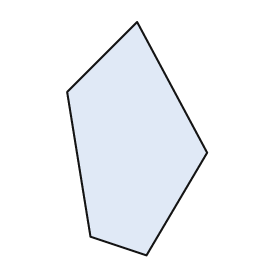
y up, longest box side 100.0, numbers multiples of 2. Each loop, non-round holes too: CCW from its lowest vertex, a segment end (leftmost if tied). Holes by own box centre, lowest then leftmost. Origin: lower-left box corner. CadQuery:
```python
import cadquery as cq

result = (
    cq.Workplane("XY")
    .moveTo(34.0, 0.0)
    .lineTo(60.0, 44.0)
    .lineTo(30.0, 100.0)
    .lineTo(0.0, 70.0)
    .lineTo(10.0, 8.0)
    .close()
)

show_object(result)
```